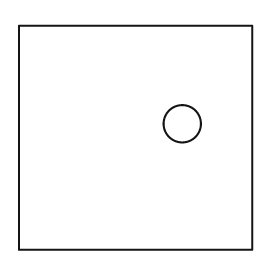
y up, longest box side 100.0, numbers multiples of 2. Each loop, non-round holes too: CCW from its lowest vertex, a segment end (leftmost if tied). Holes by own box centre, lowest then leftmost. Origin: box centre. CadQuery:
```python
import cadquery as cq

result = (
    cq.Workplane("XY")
    .moveTo(-50.0, -48.0)
    .lineTo(50.0, -48.0)
    .lineTo(50.0, 48.0)
    .lineTo(-50.0, 48.0)
    .close()
    .moveTo(20.0, 6.0)
    .circle(8.0)
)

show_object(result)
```